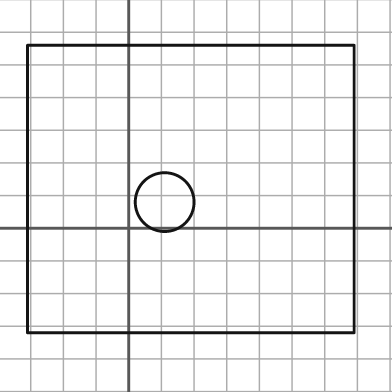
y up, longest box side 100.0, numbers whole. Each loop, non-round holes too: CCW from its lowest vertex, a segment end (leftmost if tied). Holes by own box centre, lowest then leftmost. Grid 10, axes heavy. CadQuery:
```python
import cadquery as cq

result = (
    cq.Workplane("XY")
    .moveTo(-31.0, -32.0)
    .lineTo(69.0, -32.0)
    .lineTo(69.0, 56.0)
    .lineTo(-31.0, 56.0)
    .close()
    .moveTo(11.0, 8.0)
    .circle(9.0)
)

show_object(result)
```